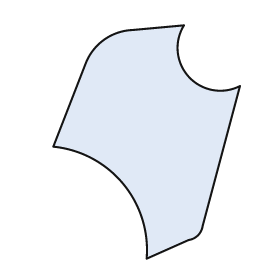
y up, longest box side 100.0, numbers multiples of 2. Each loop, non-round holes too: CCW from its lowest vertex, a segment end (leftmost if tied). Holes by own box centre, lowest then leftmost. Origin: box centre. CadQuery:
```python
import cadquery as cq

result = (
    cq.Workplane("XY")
    .moveTo(0.0, -50.0)
    .lineTo(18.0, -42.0)
    .threePointArc((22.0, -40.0), (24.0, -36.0))
    .lineTo(40.0, 24.0)
    .threePointArc((18.0, 28.0), (16.0, 50.0))
    .lineTo(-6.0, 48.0)
    .threePointArc((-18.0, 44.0), (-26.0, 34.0))
    .lineTo(-40.0, -2.0)
    .threePointArc((-10.0, -18.0), (0.0, -50.0))
    .close()
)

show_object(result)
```